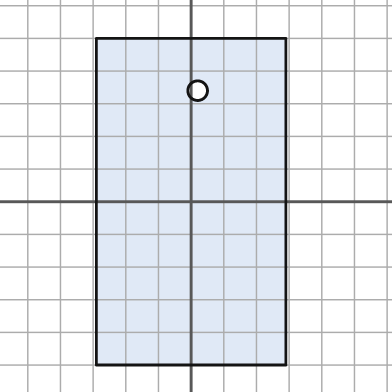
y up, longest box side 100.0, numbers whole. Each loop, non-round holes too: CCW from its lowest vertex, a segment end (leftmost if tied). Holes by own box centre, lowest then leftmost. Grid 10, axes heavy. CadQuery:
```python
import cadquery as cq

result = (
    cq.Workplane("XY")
    .moveTo(-29.0, -50.0)
    .lineTo(29.0, -50.0)
    .lineTo(29.0, 50.0)
    .lineTo(-29.0, 50.0)
    .close()
    .moveTo(2.0, 34.0)
    .circle(3.0)
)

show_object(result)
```